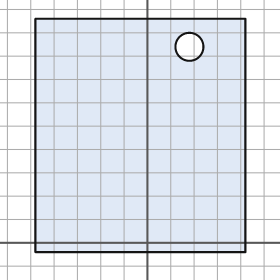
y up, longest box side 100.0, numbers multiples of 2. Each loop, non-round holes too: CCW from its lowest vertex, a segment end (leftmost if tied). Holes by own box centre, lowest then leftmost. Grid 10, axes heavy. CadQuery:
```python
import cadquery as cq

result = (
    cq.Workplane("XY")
    .moveTo(-48.0, -4.0)
    .lineTo(42.0, -4.0)
    .lineTo(42.0, 96.0)
    .lineTo(-48.0, 96.0)
    .close()
    .moveTo(18.0, 84.0)
    .circle(6.0)
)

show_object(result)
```